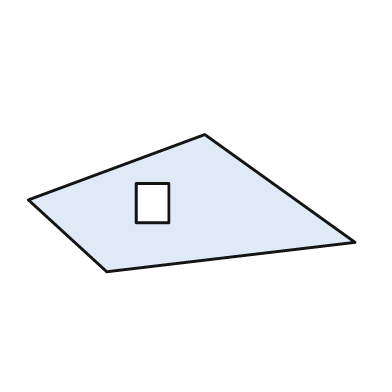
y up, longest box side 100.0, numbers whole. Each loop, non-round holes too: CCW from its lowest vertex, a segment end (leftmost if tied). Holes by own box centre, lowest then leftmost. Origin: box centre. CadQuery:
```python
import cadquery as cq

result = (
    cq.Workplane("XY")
    .moveTo(-26.0, -21.0)
    .lineTo(50.0, -12.0)
    .lineTo(4.0, 21.0)
    .lineTo(-50.0, 1.0)
    .close()
    .moveTo(-17.0, -6.0)
    .lineTo(-7.0, -6.0)
    .lineTo(-7.0, 6.0)
    .lineTo(-17.0, 6.0)
    .close()
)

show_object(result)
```